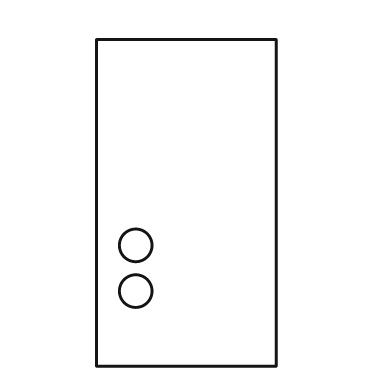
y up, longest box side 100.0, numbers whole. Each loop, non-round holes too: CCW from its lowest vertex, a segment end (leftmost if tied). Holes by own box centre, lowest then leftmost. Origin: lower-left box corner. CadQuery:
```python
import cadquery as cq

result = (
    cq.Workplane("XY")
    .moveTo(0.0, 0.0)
    .lineTo(55.0, 0.0)
    .lineTo(55.0, 100.0)
    .lineTo(0.0, 100.0)
    .close()
    .moveTo(12.0, 23.0)
    .circle(5.0)
    .moveTo(12.0, 37.0)
    .circle(5.0)
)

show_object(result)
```